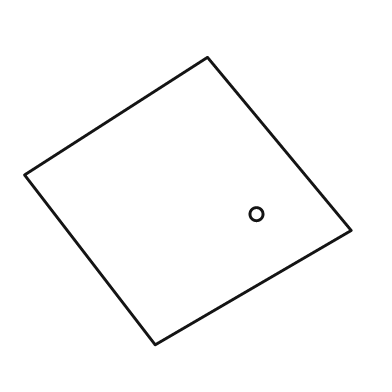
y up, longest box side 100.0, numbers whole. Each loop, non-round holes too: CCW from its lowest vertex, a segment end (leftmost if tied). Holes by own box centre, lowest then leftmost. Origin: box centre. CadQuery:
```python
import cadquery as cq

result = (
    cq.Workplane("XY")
    .moveTo(-10.0, -44.0)
    .lineTo(50.0, -9.0)
    .lineTo(6.0, 44.0)
    .lineTo(-50.0, 8.0)
    .close()
    .moveTo(21.0, -4.0)
    .circle(2.0)
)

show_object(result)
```